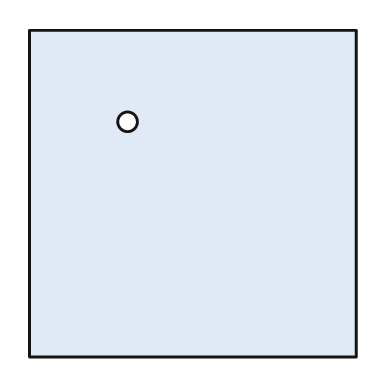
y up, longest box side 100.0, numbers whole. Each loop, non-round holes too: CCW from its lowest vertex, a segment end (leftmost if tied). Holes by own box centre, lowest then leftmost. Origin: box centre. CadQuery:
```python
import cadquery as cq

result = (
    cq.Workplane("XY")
    .moveTo(-50.0, -50.0)
    .lineTo(50.0, -50.0)
    .lineTo(50.0, 50.0)
    .lineTo(-50.0, 50.0)
    .close()
    .moveTo(-20.0, 22.0)
    .circle(3.0)
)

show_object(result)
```